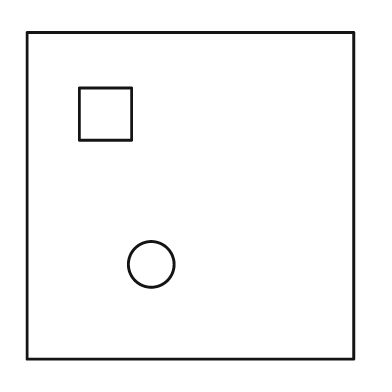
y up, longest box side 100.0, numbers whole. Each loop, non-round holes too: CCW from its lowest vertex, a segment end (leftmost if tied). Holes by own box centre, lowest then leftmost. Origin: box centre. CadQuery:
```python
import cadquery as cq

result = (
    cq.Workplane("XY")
    .moveTo(-50.0, -50.0)
    .lineTo(50.0, -50.0)
    .lineTo(50.0, 50.0)
    .lineTo(-50.0, 50.0)
    .close()
    .moveTo(-12.0, -21.0)
    .circle(7.0)
    .moveTo(-34.0, 17.0)
    .lineTo(-18.0, 17.0)
    .lineTo(-18.0, 33.0)
    .lineTo(-34.0, 33.0)
    .close()
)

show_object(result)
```